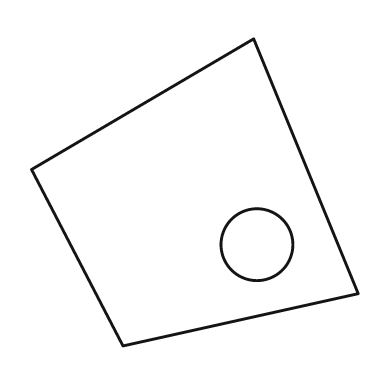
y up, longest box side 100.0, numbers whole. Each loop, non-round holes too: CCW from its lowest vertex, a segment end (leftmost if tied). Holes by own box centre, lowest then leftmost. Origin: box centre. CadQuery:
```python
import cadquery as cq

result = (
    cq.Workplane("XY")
    .moveTo(-22.0, -47.0)
    .lineTo(50.0, -31.0)
    .lineTo(18.0, 47.0)
    .lineTo(-50.0, 7.0)
    .close()
    .moveTo(19.0, -16.0)
    .circle(11.0)
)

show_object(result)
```